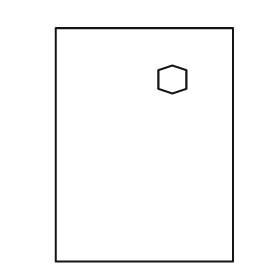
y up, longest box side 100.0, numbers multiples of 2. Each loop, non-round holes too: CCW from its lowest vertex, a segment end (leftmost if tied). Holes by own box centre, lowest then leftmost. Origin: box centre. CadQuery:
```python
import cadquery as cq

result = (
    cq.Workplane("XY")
    .moveTo(-38.0, -50.0)
    .lineTo(38.0, -50.0)
    .lineTo(38.0, 50.0)
    .lineTo(-38.0, 50.0)
    .close()
    .moveTo(12.0, 22.0)
    .lineTo(18.0, 24.0)
    .lineTo(18.0, 32.0)
    .lineTo(12.0, 34.0)
    .lineTo(6.0, 32.0)
    .lineTo(6.0, 24.0)
    .close()
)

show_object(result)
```